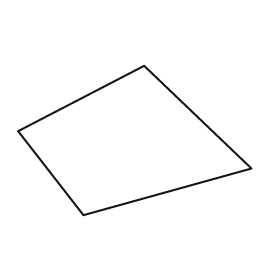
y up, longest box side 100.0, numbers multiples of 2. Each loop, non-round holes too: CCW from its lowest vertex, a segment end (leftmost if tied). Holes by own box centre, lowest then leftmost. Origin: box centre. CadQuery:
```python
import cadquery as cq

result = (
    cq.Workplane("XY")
    .moveTo(-22.0, -32.0)
    .lineTo(50.0, -12.0)
    .lineTo(4.0, 32.0)
    .lineTo(-50.0, 4.0)
    .close()
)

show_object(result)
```